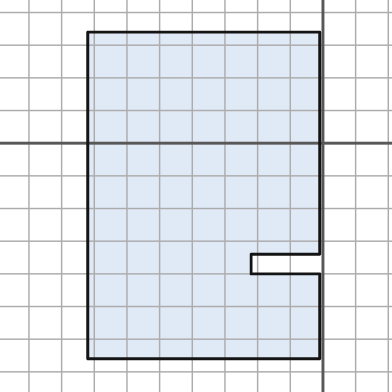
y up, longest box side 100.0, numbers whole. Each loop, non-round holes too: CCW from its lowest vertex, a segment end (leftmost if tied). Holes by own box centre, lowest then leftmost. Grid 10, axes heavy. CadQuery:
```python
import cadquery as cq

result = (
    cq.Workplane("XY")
    .moveTo(-72.0, -66.0)
    .lineTo(-1.0, -66.0)
    .lineTo(-1.0, -40.0)
    .lineTo(-22.0, -40.0)
    .lineTo(-22.0, -34.0)
    .lineTo(-1.0, -34.0)
    .lineTo(-1.0, 34.0)
    .lineTo(-72.0, 34.0)
    .close()
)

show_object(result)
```